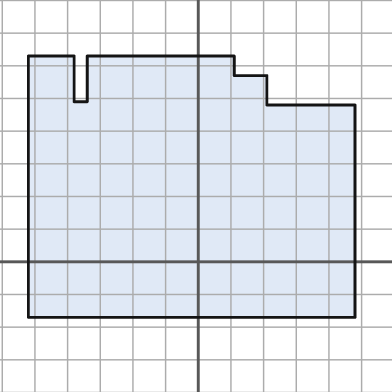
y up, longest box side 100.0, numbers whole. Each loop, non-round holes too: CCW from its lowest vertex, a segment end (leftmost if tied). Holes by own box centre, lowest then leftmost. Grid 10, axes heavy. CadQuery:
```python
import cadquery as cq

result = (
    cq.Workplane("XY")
    .moveTo(-52.0, -17.0)
    .lineTo(48.0, -17.0)
    .lineTo(48.0, 48.0)
    .lineTo(21.0, 48.0)
    .lineTo(21.0, 57.0)
    .lineTo(11.0, 57.0)
    .lineTo(11.0, 63.0)
    .lineTo(-34.0, 63.0)
    .lineTo(-34.0, 49.0)
    .lineTo(-38.0, 49.0)
    .lineTo(-38.0, 63.0)
    .lineTo(-52.0, 63.0)
    .close()
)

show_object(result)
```